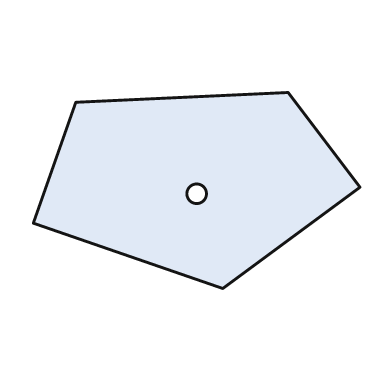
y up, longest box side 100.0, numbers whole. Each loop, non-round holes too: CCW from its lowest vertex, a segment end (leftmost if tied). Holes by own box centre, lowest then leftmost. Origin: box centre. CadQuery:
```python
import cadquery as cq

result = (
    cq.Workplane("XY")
    .moveTo(8.0, -30.0)
    .lineTo(50.0, 1.0)
    .lineTo(28.0, 30.0)
    .lineTo(-37.0, 27.0)
    .lineTo(-50.0, -10.0)
    .close()
    .moveTo(0.0, -1.0)
    .circle(3.0)
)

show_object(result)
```